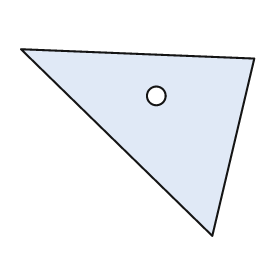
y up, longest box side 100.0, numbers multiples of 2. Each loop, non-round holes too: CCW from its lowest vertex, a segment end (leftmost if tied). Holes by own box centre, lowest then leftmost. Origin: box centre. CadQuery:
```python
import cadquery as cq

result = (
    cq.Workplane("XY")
    .moveTo(32.0, -40.0)
    .lineTo(50.0, 36.0)
    .lineTo(-50.0, 40.0)
    .close()
    .moveTo(8.0, 20.0)
    .circle(4.0)
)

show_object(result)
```